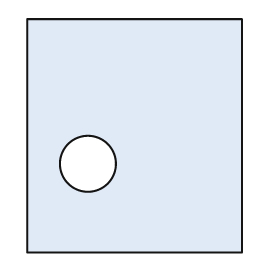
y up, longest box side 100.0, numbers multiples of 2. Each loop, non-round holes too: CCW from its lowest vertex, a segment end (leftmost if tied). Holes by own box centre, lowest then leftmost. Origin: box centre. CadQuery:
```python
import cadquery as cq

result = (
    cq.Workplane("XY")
    .moveTo(-46.0, -50.0)
    .lineTo(46.0, -50.0)
    .lineTo(46.0, 50.0)
    .lineTo(-46.0, 50.0)
    .close()
    .moveTo(-20.0, -12.0)
    .circle(12.0)
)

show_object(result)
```